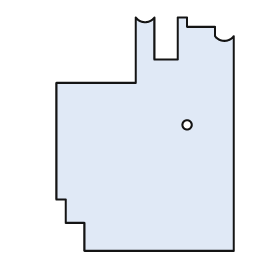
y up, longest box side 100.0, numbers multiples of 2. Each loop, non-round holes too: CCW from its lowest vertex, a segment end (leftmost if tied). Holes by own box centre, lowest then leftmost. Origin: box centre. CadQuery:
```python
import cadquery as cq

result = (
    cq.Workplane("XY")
    .moveTo(-26.0, -50.0)
    .lineTo(38.0, -50.0)
    .lineTo(38.0, 42.0)
    .threePointArc((34.0, 40.0), (30.0, 42.0))
    .lineTo(30.0, 46.0)
    .lineTo(18.0, 46.0)
    .lineTo(18.0, 50.0)
    .lineTo(14.0, 50.0)
    .lineTo(14.0, 32.0)
    .lineTo(4.0, 32.0)
    .lineTo(4.0, 50.0)
    .threePointArc((0.0, 48.0), (-4.0, 50.0))
    .lineTo(-4.0, 22.0)
    .lineTo(-38.0, 22.0)
    .lineTo(-38.0, -28.0)
    .lineTo(-34.0, -28.0)
    .lineTo(-34.0, -38.0)
    .lineTo(-26.0, -38.0)
    .close()
    .moveTo(18.0, 4.0)
    .circle(2.0)
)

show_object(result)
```